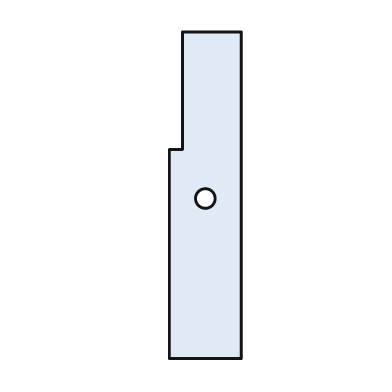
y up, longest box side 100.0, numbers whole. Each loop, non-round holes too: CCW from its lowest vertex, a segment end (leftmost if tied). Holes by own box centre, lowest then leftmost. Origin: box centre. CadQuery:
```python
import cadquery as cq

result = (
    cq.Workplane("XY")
    .moveTo(-11.0, -50.0)
    .lineTo(11.0, -50.0)
    .lineTo(11.0, 50.0)
    .lineTo(-7.0, 50.0)
    .lineTo(-7.0, 14.0)
    .lineTo(-11.0, 14.0)
    .close()
    .moveTo(0.0, -1.0)
    .circle(3.0)
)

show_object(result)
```